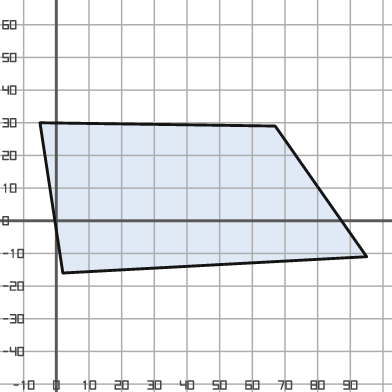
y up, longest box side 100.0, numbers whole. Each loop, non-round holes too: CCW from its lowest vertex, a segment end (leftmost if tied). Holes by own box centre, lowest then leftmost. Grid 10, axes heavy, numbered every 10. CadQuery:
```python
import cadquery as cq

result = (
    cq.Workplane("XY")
    .moveTo(2.0, -16.0)
    .lineTo(95.0, -11.0)
    .lineTo(67.0, 29.0)
    .lineTo(-5.0, 30.0)
    .close()
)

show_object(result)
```